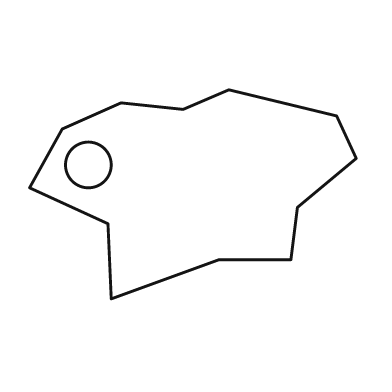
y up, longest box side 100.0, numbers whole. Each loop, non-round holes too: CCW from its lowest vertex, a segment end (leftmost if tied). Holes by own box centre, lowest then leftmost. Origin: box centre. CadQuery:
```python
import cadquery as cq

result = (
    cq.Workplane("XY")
    .moveTo(-25.0, -32.0)
    .lineTo(8.0, -20.0)
    .lineTo(30.0, -20.0)
    .lineTo(32.0, -4.0)
    .lineTo(50.0, 11.0)
    .lineTo(44.0, 24.0)
    .lineTo(11.0, 32.0)
    .lineTo(-3.0, 26.0)
    .lineTo(-22.0, 28.0)
    .lineTo(-40.0, 20.0)
    .lineTo(-50.0, 2.0)
    .lineTo(-26.0, -9.0)
    .close()
    .moveTo(-32.0, 9.0)
    .circle(7.0)
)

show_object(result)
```